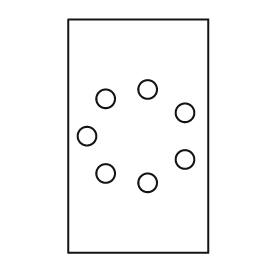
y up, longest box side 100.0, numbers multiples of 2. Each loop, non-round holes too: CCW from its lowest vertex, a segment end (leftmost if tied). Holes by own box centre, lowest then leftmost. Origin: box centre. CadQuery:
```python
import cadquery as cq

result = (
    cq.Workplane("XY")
    .moveTo(-30.0, -50.0)
    .lineTo(30.0, -50.0)
    .lineTo(30.0, 50.0)
    .lineTo(-30.0, 50.0)
    .close()
    .moveTo(4.0, -20.0)
    .circle(4.0)
    .moveTo(-14.0, -16.0)
    .circle(4.0)
    .moveTo(20.0, -10.0)
    .circle(4.0)
    .moveTo(-22.0, 0.0)
    .circle(4.0)
    .moveTo(20.0, 10.0)
    .circle(4.0)
    .moveTo(-14.0, 16.0)
    .circle(4.0)
    .moveTo(4.0, 20.0)
    .circle(4.0)
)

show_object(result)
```